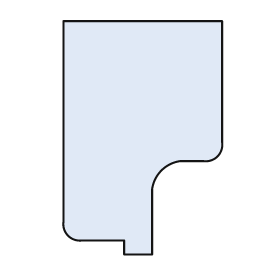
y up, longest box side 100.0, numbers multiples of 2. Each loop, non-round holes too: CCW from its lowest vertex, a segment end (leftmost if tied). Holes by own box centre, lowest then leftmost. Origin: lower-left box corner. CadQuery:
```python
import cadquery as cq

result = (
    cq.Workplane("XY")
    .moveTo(26.0, 0.0)
    .lineTo(38.0, 0.0)
    .lineTo(38.0, 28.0)
    .threePointArc((42.0, 36.0), (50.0, 40.0))
    .lineTo(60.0, 40.0)
    .threePointArc((66.0, 42.0), (68.0, 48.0))
    .lineTo(68.0, 100.0)
    .lineTo(0.0, 100.0)
    .lineTo(0.0, 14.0)
    .threePointArc((2.0, 8.0), (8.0, 6.0))
    .lineTo(26.0, 6.0)
    .close()
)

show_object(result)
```